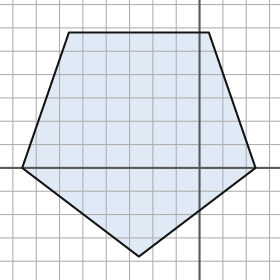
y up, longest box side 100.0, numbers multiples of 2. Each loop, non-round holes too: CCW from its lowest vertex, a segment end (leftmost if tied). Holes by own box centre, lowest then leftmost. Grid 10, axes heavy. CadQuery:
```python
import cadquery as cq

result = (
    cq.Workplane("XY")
    .moveTo(-26.0, -38.0)
    .lineTo(24.0, 0.0)
    .lineTo(4.0, 58.0)
    .lineTo(-56.0, 58.0)
    .lineTo(-76.0, 0.0)
    .close()
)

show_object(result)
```